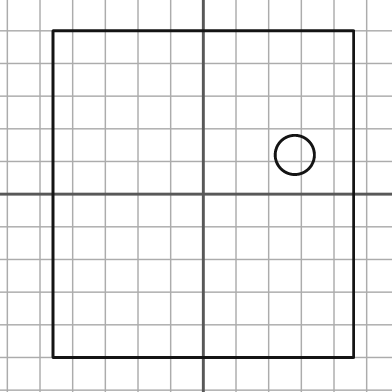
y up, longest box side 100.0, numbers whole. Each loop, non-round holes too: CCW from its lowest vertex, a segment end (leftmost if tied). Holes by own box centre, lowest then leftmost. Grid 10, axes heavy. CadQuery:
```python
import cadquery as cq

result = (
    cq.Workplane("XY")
    .moveTo(-46.0, -50.0)
    .lineTo(46.0, -50.0)
    .lineTo(46.0, 50.0)
    .lineTo(-46.0, 50.0)
    .close()
    .moveTo(28.0, 12.0)
    .circle(6.0)
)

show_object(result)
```